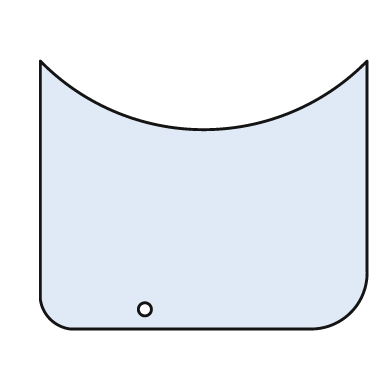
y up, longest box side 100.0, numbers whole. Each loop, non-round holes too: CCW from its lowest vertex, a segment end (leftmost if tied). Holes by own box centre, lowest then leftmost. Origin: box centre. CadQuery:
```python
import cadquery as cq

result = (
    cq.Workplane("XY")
    .moveTo(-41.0, -41.0)
    .lineTo(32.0, -41.0)
    .threePointArc((45.0, -36.0), (50.0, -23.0))
    .lineTo(50.0, 41.0)
    .threePointArc((0.0, 20.0), (-50.0, 41.0))
    .lineTo(-50.0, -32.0)
    .threePointArc((-47.0, -38.0), (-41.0, -41.0))
    .close()
    .moveTo(-18.0, -35.0)
    .circle(2.0)
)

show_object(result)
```